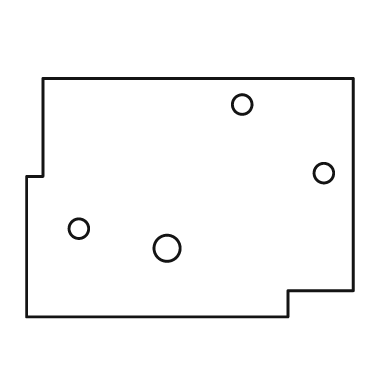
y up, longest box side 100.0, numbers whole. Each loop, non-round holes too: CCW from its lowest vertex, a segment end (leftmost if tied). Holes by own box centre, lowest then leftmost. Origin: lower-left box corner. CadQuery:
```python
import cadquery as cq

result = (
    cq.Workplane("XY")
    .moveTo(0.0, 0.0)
    .lineTo(80.0, 0.0)
    .lineTo(80.0, 8.0)
    .lineTo(100.0, 8.0)
    .lineTo(100.0, 73.0)
    .lineTo(5.0, 73.0)
    .lineTo(5.0, 43.0)
    .lineTo(0.0, 43.0)
    .close()
    .moveTo(43.0, 21.0)
    .circle(4.0)
    .moveTo(16.0, 27.0)
    .circle(3.0)
    .moveTo(91.0, 44.0)
    .circle(3.0)
    .moveTo(66.0, 65.0)
    .circle(3.0)
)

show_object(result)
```